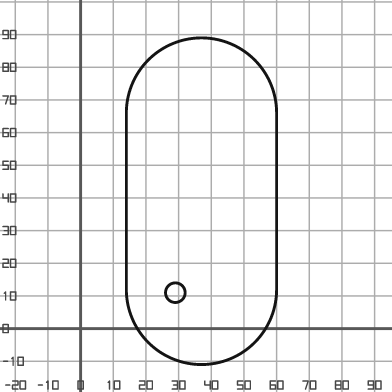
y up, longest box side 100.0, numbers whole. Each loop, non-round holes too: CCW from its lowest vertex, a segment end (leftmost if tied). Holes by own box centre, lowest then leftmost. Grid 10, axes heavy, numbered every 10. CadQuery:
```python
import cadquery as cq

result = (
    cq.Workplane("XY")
    .moveTo(14.0, 12.0)
    .threePointArc((37.0, -11.0), (60.0, 12.0))
    .lineTo(60.0, 66.0)
    .threePointArc((37.0, 89.0), (14.0, 66.0))
    .close()
    .moveTo(29.0, 11.0)
    .circle(3.0)
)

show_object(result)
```